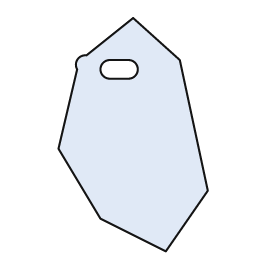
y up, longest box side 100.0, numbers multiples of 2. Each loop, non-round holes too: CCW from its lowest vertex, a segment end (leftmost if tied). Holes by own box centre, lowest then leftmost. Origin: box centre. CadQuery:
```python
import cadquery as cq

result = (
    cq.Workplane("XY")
    .moveTo(14.0, -50.0)
    .lineTo(32.0, -24.0)
    .lineTo(20.0, 32.0)
    .lineTo(0.0, 50.0)
    .lineTo(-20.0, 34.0)
    .threePointArc((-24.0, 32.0), (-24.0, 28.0))
    .lineTo(-32.0, -6.0)
    .lineTo(-14.0, -36.0)
    .close()
    .moveTo(-10.0, 24.0)
    .lineTo(-2.0, 24.0)
    .threePointArc((2.0, 28.0), (-2.0, 32.0))
    .lineTo(-10.0, 32.0)
    .threePointArc((-14.0, 28.0), (-10.0, 24.0))
    .close()
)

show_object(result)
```